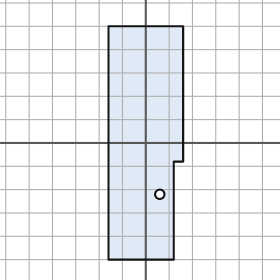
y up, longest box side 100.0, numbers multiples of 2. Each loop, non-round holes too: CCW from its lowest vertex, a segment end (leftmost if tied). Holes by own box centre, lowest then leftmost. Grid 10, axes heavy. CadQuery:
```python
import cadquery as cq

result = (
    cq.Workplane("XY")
    .moveTo(-16.0, -50.0)
    .lineTo(12.0, -50.0)
    .lineTo(12.0, -8.0)
    .lineTo(16.0, -8.0)
    .lineTo(16.0, 50.0)
    .lineTo(-16.0, 50.0)
    .close()
    .moveTo(6.0, -22.0)
    .circle(2.0)
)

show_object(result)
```